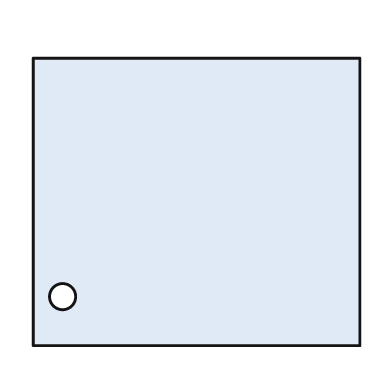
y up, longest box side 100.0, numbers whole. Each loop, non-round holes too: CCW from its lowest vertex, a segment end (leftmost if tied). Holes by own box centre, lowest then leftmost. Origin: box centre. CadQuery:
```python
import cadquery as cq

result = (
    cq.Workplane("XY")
    .moveTo(-50.0, -44.0)
    .lineTo(50.0, -44.0)
    .lineTo(50.0, 44.0)
    .lineTo(-50.0, 44.0)
    .close()
    .moveTo(-41.0, -29.0)
    .circle(4.0)
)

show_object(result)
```